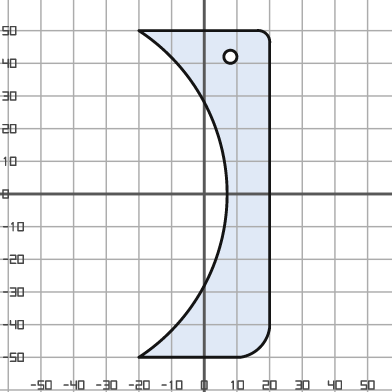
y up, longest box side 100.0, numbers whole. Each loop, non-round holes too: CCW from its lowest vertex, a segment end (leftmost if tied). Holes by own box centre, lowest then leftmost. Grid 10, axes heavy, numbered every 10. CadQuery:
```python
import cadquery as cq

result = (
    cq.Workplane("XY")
    .moveTo(-20.0, -50.0)
    .lineTo(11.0, -50.0)
    .threePointArc((17.0, -47.0), (20.0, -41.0))
    .lineTo(20.0, 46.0)
    .threePointArc((19.0, 49.0), (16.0, 50.0))
    .lineTo(-20.0, 50.0)
    .threePointArc((7.0, 0.0), (-20.0, -50.0))
    .close()
    .moveTo(8.0, 42.0)
    .circle(2.0)
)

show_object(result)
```